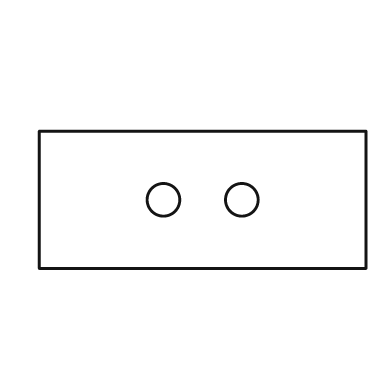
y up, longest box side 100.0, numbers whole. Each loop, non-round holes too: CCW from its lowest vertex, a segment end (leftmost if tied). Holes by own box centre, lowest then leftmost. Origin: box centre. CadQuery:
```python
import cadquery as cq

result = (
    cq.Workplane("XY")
    .moveTo(-50.0, -21.0)
    .lineTo(50.0, -21.0)
    .lineTo(50.0, 21.0)
    .lineTo(-50.0, 21.0)
    .close()
    .moveTo(-12.0, 0.0)
    .circle(5.0)
    .moveTo(12.0, 0.0)
    .circle(5.0)
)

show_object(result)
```